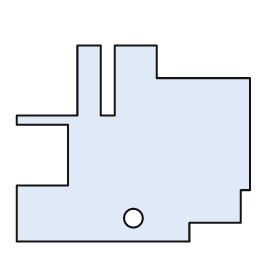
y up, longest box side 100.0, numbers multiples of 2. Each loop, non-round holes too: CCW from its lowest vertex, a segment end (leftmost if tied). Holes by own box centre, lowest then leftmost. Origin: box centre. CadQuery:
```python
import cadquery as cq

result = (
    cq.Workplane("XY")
    .moveTo(-50.0, -42.0)
    .lineTo(24.0, -42.0)
    .lineTo(24.0, -34.0)
    .lineTo(46.0, -34.0)
    .lineTo(46.0, -20.0)
    .lineTo(50.0, -20.0)
    .lineTo(50.0, 28.0)
    .lineTo(10.0, 28.0)
    .lineTo(10.0, 42.0)
    .lineTo(-8.0, 42.0)
    .lineTo(-8.0, 12.0)
    .lineTo(-14.0, 12.0)
    .lineTo(-14.0, 42.0)
    .lineTo(-24.0, 42.0)
    .lineTo(-24.0, 12.0)
    .lineTo(-50.0, 12.0)
    .lineTo(-50.0, 8.0)
    .lineTo(-28.0, 8.0)
    .lineTo(-28.0, -18.0)
    .lineTo(-50.0, -18.0)
    .close()
    .moveTo(0.0, -32.0)
    .circle(4.0)
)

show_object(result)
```